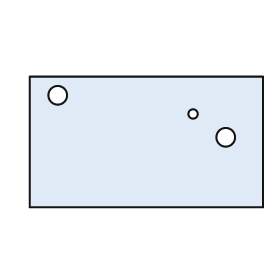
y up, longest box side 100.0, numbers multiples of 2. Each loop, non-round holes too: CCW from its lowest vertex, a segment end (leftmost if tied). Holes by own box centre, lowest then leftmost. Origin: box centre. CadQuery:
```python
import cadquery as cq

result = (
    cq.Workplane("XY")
    .moveTo(-50.0, -28.0)
    .lineTo(50.0, -28.0)
    .lineTo(50.0, 28.0)
    .lineTo(-50.0, 28.0)
    .close()
    .moveTo(34.0, 2.0)
    .circle(4.0)
    .moveTo(20.0, 12.0)
    .circle(2.0)
    .moveTo(-38.0, 20.0)
    .circle(4.0)
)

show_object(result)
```